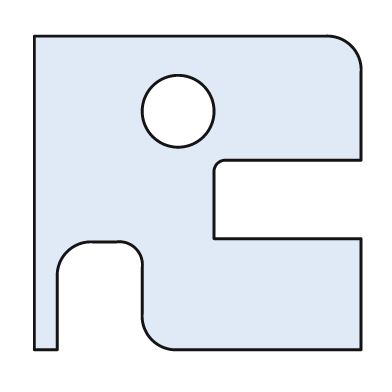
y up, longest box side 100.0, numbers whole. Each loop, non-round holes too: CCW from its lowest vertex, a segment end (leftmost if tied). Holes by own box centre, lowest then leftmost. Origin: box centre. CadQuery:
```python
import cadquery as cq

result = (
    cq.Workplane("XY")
    .moveTo(-50.0, -48.0)
    .lineTo(-43.0, -48.0)
    .lineTo(-43.0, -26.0)
    .threePointArc((-40.0, -18.0), (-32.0, -15.0))
    .lineTo(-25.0, -15.0)
    .threePointArc((-19.0, -17.0), (-17.0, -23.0))
    .lineTo(-17.0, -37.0)
    .threePointArc((-14.0, -45.0), (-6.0, -48.0))
    .lineTo(50.0, -48.0)
    .lineTo(50.0, -14.0)
    .lineTo(5.0, -14.0)
    .lineTo(5.0, 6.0)
    .threePointArc((6.0, 9.0), (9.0, 10.0))
    .lineTo(50.0, 10.0)
    .lineTo(50.0, 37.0)
    .threePointArc((47.0, 45.0), (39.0, 48.0))
    .lineTo(-50.0, 48.0)
    .close()
    .moveTo(-6.0, 25.0)
    .circle(11.0)
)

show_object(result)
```